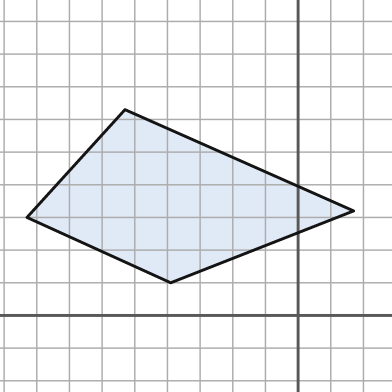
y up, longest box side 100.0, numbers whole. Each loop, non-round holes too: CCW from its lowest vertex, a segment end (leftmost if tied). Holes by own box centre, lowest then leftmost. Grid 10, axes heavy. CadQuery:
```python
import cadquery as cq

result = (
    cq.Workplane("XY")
    .moveTo(-39.0, 10.0)
    .lineTo(17.0, 32.0)
    .lineTo(-53.0, 63.0)
    .lineTo(-83.0, 30.0)
    .close()
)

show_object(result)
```